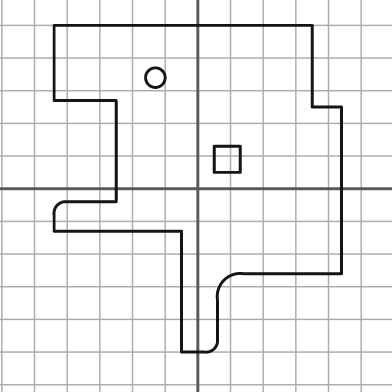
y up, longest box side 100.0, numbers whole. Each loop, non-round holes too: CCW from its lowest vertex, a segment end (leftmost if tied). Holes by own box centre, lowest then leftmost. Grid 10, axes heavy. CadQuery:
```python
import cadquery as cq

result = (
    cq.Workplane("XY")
    .moveTo(-5.0, -50.0)
    .lineTo(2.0, -50.0)
    .threePointArc((5.0, -49.0), (6.0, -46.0))
    .lineTo(6.0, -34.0)
    .threePointArc((8.0, -28.0), (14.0, -26.0))
    .lineTo(44.0, -26.0)
    .lineTo(44.0, 25.0)
    .lineTo(35.0, 25.0)
    .lineTo(35.0, 50.0)
    .lineTo(-44.0, 50.0)
    .lineTo(-44.0, 27.0)
    .lineTo(-25.0, 27.0)
    .lineTo(-25.0, -4.0)
    .lineTo(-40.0, -4.0)
    .threePointArc((-43.0, -5.0), (-44.0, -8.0))
    .lineTo(-44.0, -13.0)
    .lineTo(-5.0, -13.0)
    .close()
    .moveTo(5.0, 5.0)
    .lineTo(13.0, 5.0)
    .lineTo(13.0, 13.0)
    .lineTo(5.0, 13.0)
    .close()
    .moveTo(-13.0, 34.0)
    .circle(3.0)
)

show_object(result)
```